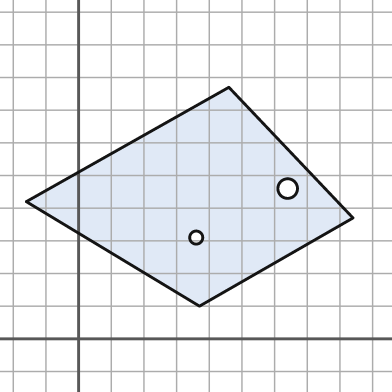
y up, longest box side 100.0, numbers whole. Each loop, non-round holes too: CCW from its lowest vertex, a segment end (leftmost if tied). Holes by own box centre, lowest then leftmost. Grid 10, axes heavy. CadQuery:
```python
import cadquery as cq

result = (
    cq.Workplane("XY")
    .moveTo(37.0, 10.0)
    .lineTo(84.0, 37.0)
    .lineTo(46.0, 77.0)
    .lineTo(-16.0, 42.0)
    .close()
    .moveTo(36.0, 31.0)
    .circle(2.0)
    .moveTo(64.0, 46.0)
    .circle(3.0)
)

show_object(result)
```